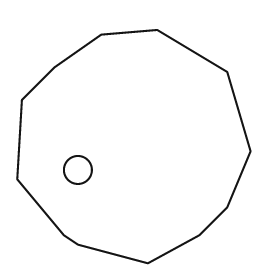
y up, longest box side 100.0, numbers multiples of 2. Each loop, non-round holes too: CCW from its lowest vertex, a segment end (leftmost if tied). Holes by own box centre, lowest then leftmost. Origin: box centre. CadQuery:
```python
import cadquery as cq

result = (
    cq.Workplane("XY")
    .moveTo(6.0, -50.0)
    .lineTo(28.0, -38.0)
    .lineTo(40.0, -26.0)
    .lineTo(50.0, -2.0)
    .lineTo(40.0, 32.0)
    .lineTo(10.0, 50.0)
    .lineTo(-14.0, 48.0)
    .lineTo(-34.0, 34.0)
    .lineTo(-48.0, 20.0)
    .lineTo(-50.0, -14.0)
    .lineTo(-30.0, -38.0)
    .lineTo(-24.0, -42.0)
    .close()
    .moveTo(-24.0, -10.0)
    .circle(6.0)
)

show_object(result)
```